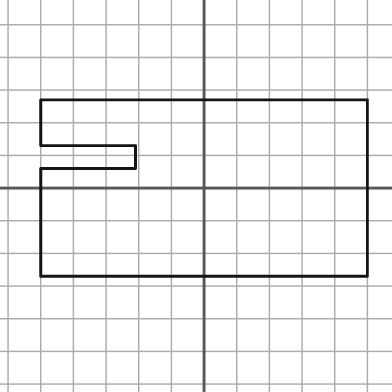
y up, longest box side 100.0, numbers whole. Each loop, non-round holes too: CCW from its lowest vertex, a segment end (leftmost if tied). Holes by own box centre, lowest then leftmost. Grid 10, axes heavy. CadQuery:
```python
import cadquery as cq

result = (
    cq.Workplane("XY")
    .moveTo(-50.0, -27.0)
    .lineTo(50.0, -27.0)
    .lineTo(50.0, 27.0)
    .lineTo(-50.0, 27.0)
    .lineTo(-50.0, 13.0)
    .lineTo(-21.0, 13.0)
    .lineTo(-21.0, 6.0)
    .lineTo(-50.0, 6.0)
    .close()
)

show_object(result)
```